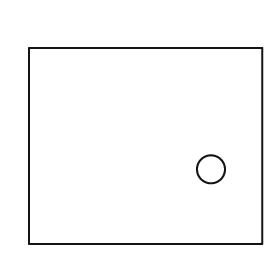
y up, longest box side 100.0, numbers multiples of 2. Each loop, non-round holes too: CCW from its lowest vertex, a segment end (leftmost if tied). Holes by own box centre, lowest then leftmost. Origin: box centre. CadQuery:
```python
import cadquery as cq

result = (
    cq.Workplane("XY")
    .moveTo(-50.0, -42.0)
    .lineTo(50.0, -42.0)
    .lineTo(50.0, 42.0)
    .lineTo(-50.0, 42.0)
    .close()
    .moveTo(28.0, -10.0)
    .circle(6.0)
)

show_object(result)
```